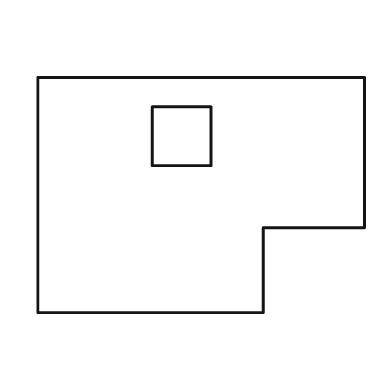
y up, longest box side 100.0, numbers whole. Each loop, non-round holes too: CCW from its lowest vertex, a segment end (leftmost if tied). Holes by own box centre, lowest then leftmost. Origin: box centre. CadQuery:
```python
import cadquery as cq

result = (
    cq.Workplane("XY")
    .moveTo(-50.0, -36.0)
    .lineTo(19.0, -36.0)
    .lineTo(19.0, -10.0)
    .lineTo(50.0, -10.0)
    .lineTo(50.0, 36.0)
    .lineTo(-50.0, 36.0)
    .close()
    .moveTo(-15.0, 9.0)
    .lineTo(3.0, 9.0)
    .lineTo(3.0, 27.0)
    .lineTo(-15.0, 27.0)
    .close()
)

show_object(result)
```